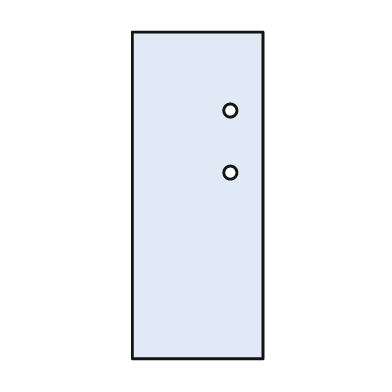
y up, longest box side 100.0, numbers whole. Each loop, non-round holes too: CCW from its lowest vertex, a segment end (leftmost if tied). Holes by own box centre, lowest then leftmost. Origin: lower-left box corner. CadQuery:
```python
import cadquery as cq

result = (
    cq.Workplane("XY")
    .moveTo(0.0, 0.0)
    .lineTo(40.0, 0.0)
    .lineTo(40.0, 100.0)
    .lineTo(0.0, 100.0)
    .close()
    .moveTo(30.0, 57.0)
    .circle(2.0)
    .moveTo(30.0, 76.0)
    .circle(2.0)
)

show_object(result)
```